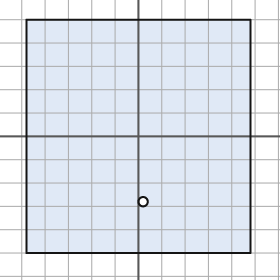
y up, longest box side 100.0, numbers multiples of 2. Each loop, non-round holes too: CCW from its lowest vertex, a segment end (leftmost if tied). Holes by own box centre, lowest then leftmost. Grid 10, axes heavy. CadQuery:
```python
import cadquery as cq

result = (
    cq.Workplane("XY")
    .moveTo(-48.0, -50.0)
    .lineTo(48.0, -50.0)
    .lineTo(48.0, 50.0)
    .lineTo(-48.0, 50.0)
    .close()
    .moveTo(2.0, -28.0)
    .circle(2.0)
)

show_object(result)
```